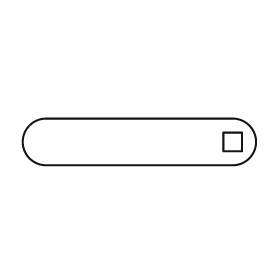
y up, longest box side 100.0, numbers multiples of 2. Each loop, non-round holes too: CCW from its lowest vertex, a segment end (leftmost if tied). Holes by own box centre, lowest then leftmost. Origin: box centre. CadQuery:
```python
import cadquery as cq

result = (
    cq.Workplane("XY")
    .moveTo(-40.0, -10.0)
    .lineTo(40.0, -10.0)
    .threePointArc((50.0, 0.0), (40.0, 10.0))
    .lineTo(-40.0, 10.0)
    .threePointArc((-50.0, 0.0), (-40.0, -10.0))
    .close()
    .moveTo(36.0, -4.0)
    .lineTo(44.0, -4.0)
    .lineTo(44.0, 4.0)
    .lineTo(36.0, 4.0)
    .close()
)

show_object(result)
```